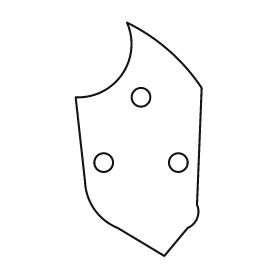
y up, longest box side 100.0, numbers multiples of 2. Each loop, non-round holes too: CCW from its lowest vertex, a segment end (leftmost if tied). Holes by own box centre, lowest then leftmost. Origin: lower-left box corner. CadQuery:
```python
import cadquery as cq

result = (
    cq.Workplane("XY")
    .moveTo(38.0, 0.0)
    .lineTo(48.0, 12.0)
    .threePointArc((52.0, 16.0), (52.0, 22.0))
    .lineTo(54.0, 72.0)
    .threePointArc((40.0, 88.0), (22.0, 100.0))
    .threePointArc((20.0, 78.0), (0.0, 68.0))
    .lineTo(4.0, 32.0)
    .threePointArc((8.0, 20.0), (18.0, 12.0))
    .close()
    .moveTo(12.0, 40.0)
    .circle(4.0)
    .moveTo(44.0, 40.0)
    .circle(4.0)
    .moveTo(28.0, 68.0)
    .circle(4.0)
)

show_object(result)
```